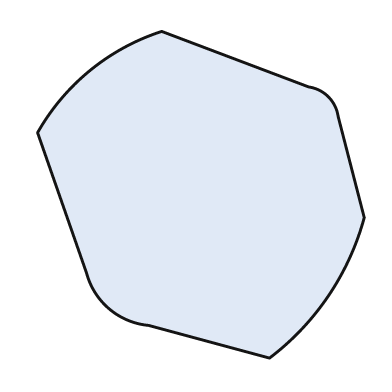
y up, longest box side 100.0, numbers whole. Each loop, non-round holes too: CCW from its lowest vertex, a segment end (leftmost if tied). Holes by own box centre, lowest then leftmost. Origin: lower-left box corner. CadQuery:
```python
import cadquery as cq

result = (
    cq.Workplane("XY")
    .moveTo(71.0, 0.0)
    .threePointArc((89.0, 19.0), (100.0, 43.0))
    .lineTo(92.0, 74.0)
    .threePointArc((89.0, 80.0), (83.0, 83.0))
    .lineTo(38.0, 100.0)
    .threePointArc((16.0, 88.0), (0.0, 69.0))
    .lineTo(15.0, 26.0)
    .threePointArc((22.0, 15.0), (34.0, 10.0))
    .close()
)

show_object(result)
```